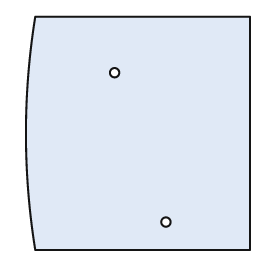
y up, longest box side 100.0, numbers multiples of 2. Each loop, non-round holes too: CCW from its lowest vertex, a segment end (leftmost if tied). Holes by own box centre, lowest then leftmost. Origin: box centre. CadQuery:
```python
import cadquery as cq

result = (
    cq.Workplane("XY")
    .moveTo(-44.0, -50.0)
    .lineTo(48.0, -50.0)
    .lineTo(48.0, 50.0)
    .lineTo(-44.0, 50.0)
    .threePointArc((-48.0, 0.0), (-44.0, -50.0))
    .close()
    .moveTo(12.0, -38.0)
    .circle(2.0)
    .moveTo(-10.0, 26.0)
    .circle(2.0)
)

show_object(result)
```